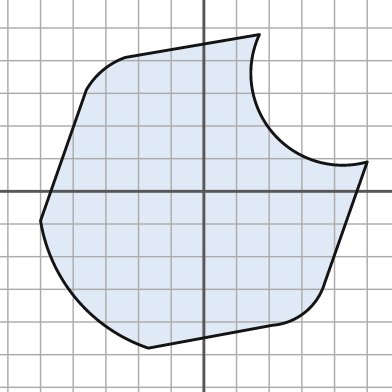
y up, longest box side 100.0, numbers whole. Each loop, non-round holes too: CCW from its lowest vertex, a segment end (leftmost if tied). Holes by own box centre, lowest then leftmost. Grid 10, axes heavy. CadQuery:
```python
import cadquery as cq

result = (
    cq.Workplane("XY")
    .moveTo(-17.0, -48.0)
    .lineTo(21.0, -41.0)
    .threePointArc((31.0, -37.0), (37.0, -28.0))
    .lineTo(50.0, 9.0)
    .threePointArc((21.0, 18.0), (17.0, 48.0))
    .lineTo(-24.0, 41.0)
    .threePointArc((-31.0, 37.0), (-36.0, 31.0))
    .lineTo(-50.0, -9.0)
    .threePointArc((-39.0, -33.0), (-17.0, -48.0))
    .close()
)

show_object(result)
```